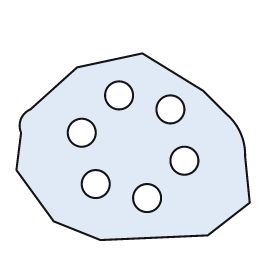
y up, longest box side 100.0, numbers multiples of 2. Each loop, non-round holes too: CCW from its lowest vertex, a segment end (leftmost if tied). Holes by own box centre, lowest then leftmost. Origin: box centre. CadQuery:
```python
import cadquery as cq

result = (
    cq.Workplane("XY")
    .moveTo(-14.0, -40.0)
    .lineTo(32.0, -38.0)
    .lineTo(50.0, -24.0)
    .lineTo(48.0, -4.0)
    .threePointArc((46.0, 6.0), (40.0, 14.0))
    .lineTo(30.0, 24.0)
    .lineTo(4.0, 40.0)
    .lineTo(-24.0, 34.0)
    .lineTo(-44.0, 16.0)
    .threePointArc((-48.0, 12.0), (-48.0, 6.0))
    .lineTo(-50.0, -10.0)
    .lineTo(-34.0, -32.0)
    .close()
    .moveTo(6.0, -22.0)
    .circle(6.0)
    .moveTo(-16.0, -16.0)
    .circle(6.0)
    .moveTo(22.0, -6.0)
    .circle(6.0)
    .moveTo(-22.0, 6.0)
    .circle(6.0)
    .moveTo(16.0, 16.0)
    .circle(6.0)
    .moveTo(-6.0, 22.0)
    .circle(6.0)
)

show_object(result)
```